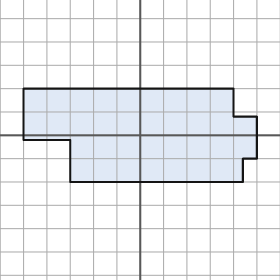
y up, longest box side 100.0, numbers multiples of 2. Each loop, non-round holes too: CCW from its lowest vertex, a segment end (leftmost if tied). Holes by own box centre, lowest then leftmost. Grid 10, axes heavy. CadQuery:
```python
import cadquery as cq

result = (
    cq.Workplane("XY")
    .moveTo(-30.0, -20.0)
    .lineTo(44.0, -20.0)
    .lineTo(44.0, -10.0)
    .lineTo(50.0, -10.0)
    .lineTo(50.0, 8.0)
    .lineTo(40.0, 8.0)
    .lineTo(40.0, 20.0)
    .lineTo(-50.0, 20.0)
    .lineTo(-50.0, -2.0)
    .lineTo(-30.0, -2.0)
    .close()
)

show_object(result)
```